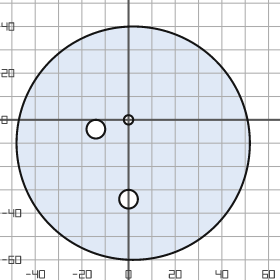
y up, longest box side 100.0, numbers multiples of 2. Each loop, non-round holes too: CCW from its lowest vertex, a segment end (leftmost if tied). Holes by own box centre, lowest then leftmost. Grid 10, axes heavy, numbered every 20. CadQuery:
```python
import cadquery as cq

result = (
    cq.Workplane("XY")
    .moveTo(2.0, -10.0)
    .circle(50.0)
    .moveTo(0.0, -34.0)
    .circle(4.0)
    .moveTo(-14.0, -4.0)
    .circle(4.0)
    .moveTo(0.0, 0.0)
    .circle(2.0)
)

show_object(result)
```